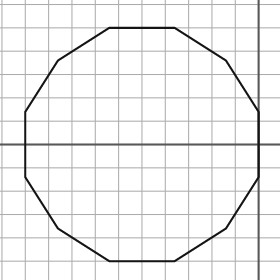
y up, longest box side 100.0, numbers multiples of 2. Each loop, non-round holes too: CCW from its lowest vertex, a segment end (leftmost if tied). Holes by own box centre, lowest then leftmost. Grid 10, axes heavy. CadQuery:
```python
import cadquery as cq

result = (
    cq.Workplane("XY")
    .moveTo(-64.0, -50.0)
    .lineTo(-36.0, -50.0)
    .lineTo(-14.0, -36.0)
    .lineTo(0.0, -14.0)
    .lineTo(0.0, 14.0)
    .lineTo(-14.0, 36.0)
    .lineTo(-36.0, 50.0)
    .lineTo(-64.0, 50.0)
    .lineTo(-86.0, 36.0)
    .lineTo(-100.0, 14.0)
    .lineTo(-100.0, -14.0)
    .lineTo(-86.0, -36.0)
    .close()
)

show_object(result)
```